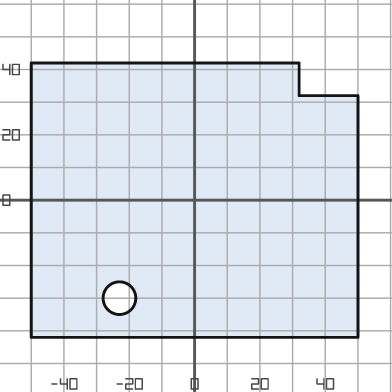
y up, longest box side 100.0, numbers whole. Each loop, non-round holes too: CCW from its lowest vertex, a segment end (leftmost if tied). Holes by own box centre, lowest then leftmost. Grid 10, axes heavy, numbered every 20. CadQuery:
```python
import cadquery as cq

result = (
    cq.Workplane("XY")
    .moveTo(-50.0, -42.0)
    .lineTo(50.0, -42.0)
    .lineTo(50.0, 32.0)
    .lineTo(32.0, 32.0)
    .lineTo(32.0, 42.0)
    .lineTo(-50.0, 42.0)
    .close()
    .moveTo(-23.0, -30.0)
    .circle(5.0)
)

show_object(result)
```